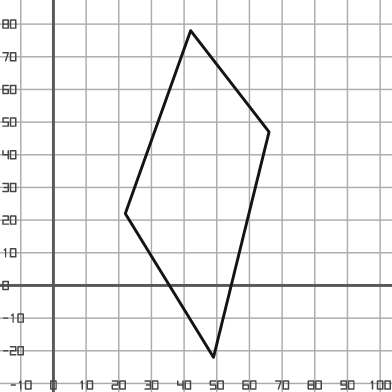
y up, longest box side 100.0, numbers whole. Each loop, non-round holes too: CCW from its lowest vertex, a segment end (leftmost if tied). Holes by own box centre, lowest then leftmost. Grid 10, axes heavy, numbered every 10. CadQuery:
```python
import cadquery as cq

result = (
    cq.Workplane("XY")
    .moveTo(49.0, -22.0)
    .lineTo(66.0, 47.0)
    .lineTo(42.0, 78.0)
    .lineTo(22.0, 22.0)
    .close()
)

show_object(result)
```